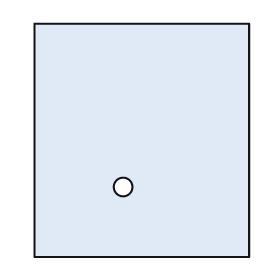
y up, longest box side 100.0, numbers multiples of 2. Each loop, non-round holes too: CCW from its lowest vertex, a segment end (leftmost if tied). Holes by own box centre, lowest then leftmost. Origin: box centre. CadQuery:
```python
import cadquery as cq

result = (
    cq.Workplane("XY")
    .moveTo(-46.0, -50.0)
    .lineTo(46.0, -50.0)
    .lineTo(46.0, 50.0)
    .lineTo(-46.0, 50.0)
    .close()
    .moveTo(-8.0, -20.0)
    .circle(4.0)
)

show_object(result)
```